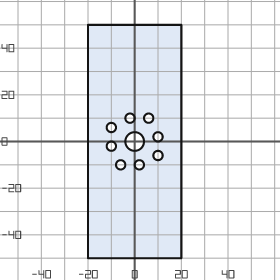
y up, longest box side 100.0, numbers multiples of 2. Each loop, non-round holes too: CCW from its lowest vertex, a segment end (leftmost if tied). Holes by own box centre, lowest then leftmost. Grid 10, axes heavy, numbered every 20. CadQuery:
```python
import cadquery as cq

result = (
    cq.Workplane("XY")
    .moveTo(-20.0, -50.0)
    .lineTo(20.0, -50.0)
    .lineTo(20.0, 50.0)
    .lineTo(-20.0, 50.0)
    .close()
    .moveTo(-6.0, -10.0)
    .circle(2.0)
    .moveTo(2.0, -10.0)
    .circle(2.0)
    .moveTo(10.0, -6.0)
    .circle(2.0)
    .moveTo(-10.0, -2.0)
    .circle(2.0)
    .moveTo(0.0, 0.0)
    .circle(4.0)
    .moveTo(10.0, 2.0)
    .circle(2.0)
    .moveTo(-10.0, 6.0)
    .circle(2.0)
    .moveTo(-2.0, 10.0)
    .circle(2.0)
    .moveTo(6.0, 10.0)
    .circle(2.0)
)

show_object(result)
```